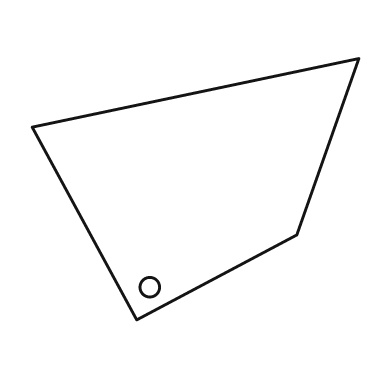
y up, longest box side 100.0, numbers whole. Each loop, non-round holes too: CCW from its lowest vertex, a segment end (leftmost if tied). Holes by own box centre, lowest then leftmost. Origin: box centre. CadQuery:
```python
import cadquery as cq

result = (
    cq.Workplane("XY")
    .moveTo(-18.0, -40.0)
    .lineTo(31.0, -14.0)
    .lineTo(50.0, 40.0)
    .lineTo(-50.0, 19.0)
    .close()
    .moveTo(-14.0, -30.0)
    .circle(3.0)
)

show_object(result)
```